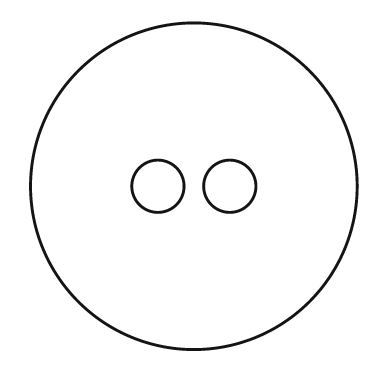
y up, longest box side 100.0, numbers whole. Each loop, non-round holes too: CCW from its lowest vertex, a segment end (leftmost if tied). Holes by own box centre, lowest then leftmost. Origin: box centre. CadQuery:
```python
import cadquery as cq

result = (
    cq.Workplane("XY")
    .moveTo(0.0, 0.0)
    .circle(50.0)
    .moveTo(-11.0, 0.0)
    .circle(8.0)
    .moveTo(11.0, 0.0)
    .circle(8.0)
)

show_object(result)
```